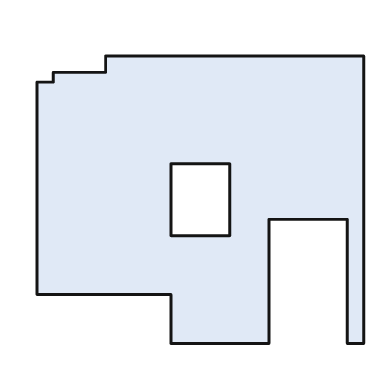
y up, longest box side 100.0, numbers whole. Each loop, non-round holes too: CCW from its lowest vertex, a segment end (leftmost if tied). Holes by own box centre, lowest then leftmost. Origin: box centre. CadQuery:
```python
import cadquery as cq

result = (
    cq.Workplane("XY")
    .moveTo(-9.0, -44.0)
    .lineTo(21.0, -44.0)
    .lineTo(21.0, -6.0)
    .lineTo(45.0, -6.0)
    .lineTo(45.0, -44.0)
    .lineTo(50.0, -44.0)
    .lineTo(50.0, 44.0)
    .lineTo(-29.0, 44.0)
    .lineTo(-29.0, 39.0)
    .lineTo(-45.0, 39.0)
    .lineTo(-45.0, 36.0)
    .lineTo(-50.0, 36.0)
    .lineTo(-50.0, -29.0)
    .lineTo(-9.0, -29.0)
    .close()
    .moveTo(-9.0, -11.0)
    .lineTo(9.0, -11.0)
    .lineTo(9.0, 11.0)
    .lineTo(-9.0, 11.0)
    .close()
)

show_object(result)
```